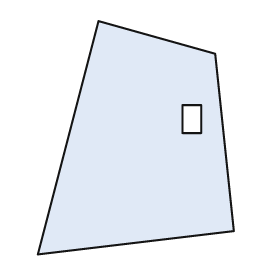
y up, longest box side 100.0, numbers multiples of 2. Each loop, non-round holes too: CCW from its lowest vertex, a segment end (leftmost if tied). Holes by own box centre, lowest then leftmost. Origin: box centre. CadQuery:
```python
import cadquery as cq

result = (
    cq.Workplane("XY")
    .moveTo(-42.0, -50.0)
    .lineTo(42.0, -40.0)
    .lineTo(34.0, 36.0)
    .lineTo(-16.0, 50.0)
    .close()
    .moveTo(20.0, 2.0)
    .lineTo(28.0, 2.0)
    .lineTo(28.0, 14.0)
    .lineTo(20.0, 14.0)
    .close()
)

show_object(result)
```